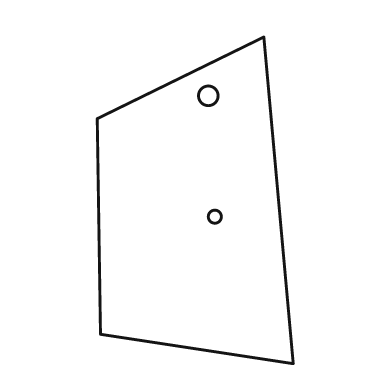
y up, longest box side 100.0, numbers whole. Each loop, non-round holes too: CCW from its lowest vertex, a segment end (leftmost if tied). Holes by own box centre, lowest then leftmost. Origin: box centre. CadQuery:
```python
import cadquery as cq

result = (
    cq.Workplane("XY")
    .moveTo(30.0, -50.0)
    .lineTo(21.0, 50.0)
    .lineTo(-30.0, 25.0)
    .lineTo(-29.0, -41.0)
    .close()
    .moveTo(6.0, -5.0)
    .circle(2.0)
    .moveTo(4.0, 32.0)
    .circle(3.0)
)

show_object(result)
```